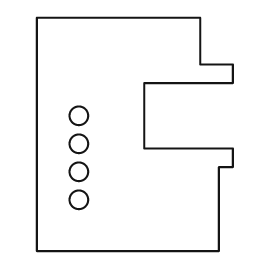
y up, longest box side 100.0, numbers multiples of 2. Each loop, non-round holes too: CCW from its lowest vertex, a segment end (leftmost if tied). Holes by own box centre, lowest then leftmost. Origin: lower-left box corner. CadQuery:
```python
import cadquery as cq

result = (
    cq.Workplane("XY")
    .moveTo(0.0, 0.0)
    .lineTo(78.0, 0.0)
    .lineTo(78.0, 36.0)
    .lineTo(84.0, 36.0)
    .lineTo(84.0, 44.0)
    .lineTo(46.0, 44.0)
    .lineTo(46.0, 72.0)
    .lineTo(84.0, 72.0)
    .lineTo(84.0, 80.0)
    .lineTo(70.0, 80.0)
    .lineTo(70.0, 100.0)
    .lineTo(0.0, 100.0)
    .close()
    .moveTo(18.0, 22.0)
    .circle(4.0)
    .moveTo(18.0, 34.0)
    .circle(4.0)
    .moveTo(18.0, 46.0)
    .circle(4.0)
    .moveTo(18.0, 58.0)
    .circle(4.0)
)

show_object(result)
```